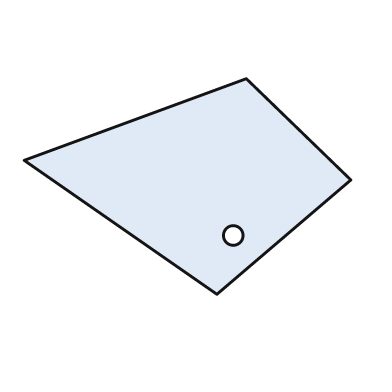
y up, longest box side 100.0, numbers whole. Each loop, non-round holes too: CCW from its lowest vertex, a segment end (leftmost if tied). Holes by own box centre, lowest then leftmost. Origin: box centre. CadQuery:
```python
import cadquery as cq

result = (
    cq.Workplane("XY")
    .moveTo(9.0, -33.0)
    .lineTo(50.0, 2.0)
    .lineTo(18.0, 33.0)
    .lineTo(-50.0, 8.0)
    .close()
    .moveTo(14.0, -15.0)
    .circle(3.0)
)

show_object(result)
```